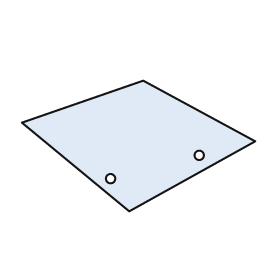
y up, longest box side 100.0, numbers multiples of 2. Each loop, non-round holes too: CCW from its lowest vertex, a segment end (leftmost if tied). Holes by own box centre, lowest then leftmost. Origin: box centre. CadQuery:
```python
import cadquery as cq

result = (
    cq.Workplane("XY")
    .moveTo(-4.0, -28.0)
    .lineTo(50.0, 2.0)
    .lineTo(2.0, 28.0)
    .lineTo(-50.0, 10.0)
    .close()
    .moveTo(-12.0, -14.0)
    .circle(2.0)
    .moveTo(26.0, -4.0)
    .circle(2.0)
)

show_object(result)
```